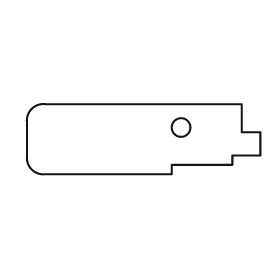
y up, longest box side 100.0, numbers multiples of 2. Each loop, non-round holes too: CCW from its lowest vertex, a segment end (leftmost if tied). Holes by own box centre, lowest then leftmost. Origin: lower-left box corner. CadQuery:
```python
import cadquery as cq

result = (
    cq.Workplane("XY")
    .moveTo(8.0, 0.0)
    .lineTo(62.0, 0.0)
    .lineTo(62.0, 4.0)
    .lineTo(88.0, 4.0)
    .lineTo(88.0, 8.0)
    .lineTo(100.0, 8.0)
    .lineTo(100.0, 18.0)
    .lineTo(92.0, 18.0)
    .lineTo(92.0, 30.0)
    .lineTo(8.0, 30.0)
    .threePointArc((2.0, 28.0), (0.0, 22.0))
    .lineTo(0.0, 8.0)
    .threePointArc((2.0, 2.0), (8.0, 0.0))
    .close()
    .moveTo(66.0, 20.0)
    .circle(4.0)
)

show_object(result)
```